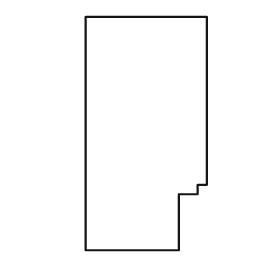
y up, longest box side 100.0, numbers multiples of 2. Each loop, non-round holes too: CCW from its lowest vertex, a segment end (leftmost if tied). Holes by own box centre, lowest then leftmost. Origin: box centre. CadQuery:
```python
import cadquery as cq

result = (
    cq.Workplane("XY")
    .moveTo(-26.0, -50.0)
    .lineTo(14.0, -50.0)
    .lineTo(14.0, -26.0)
    .lineTo(22.0, -26.0)
    .lineTo(22.0, -22.0)
    .lineTo(26.0, -22.0)
    .lineTo(26.0, 50.0)
    .lineTo(-26.0, 50.0)
    .close()
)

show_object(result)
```